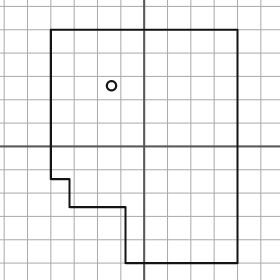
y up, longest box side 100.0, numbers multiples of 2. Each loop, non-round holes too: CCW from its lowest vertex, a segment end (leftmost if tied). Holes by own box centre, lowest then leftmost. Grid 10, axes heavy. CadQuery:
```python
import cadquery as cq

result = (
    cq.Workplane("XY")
    .moveTo(-8.0, -50.0)
    .lineTo(40.0, -50.0)
    .lineTo(40.0, 50.0)
    .lineTo(-40.0, 50.0)
    .lineTo(-40.0, -14.0)
    .lineTo(-32.0, -14.0)
    .lineTo(-32.0, -26.0)
    .lineTo(-8.0, -26.0)
    .close()
    .moveTo(-14.0, 26.0)
    .circle(2.0)
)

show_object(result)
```